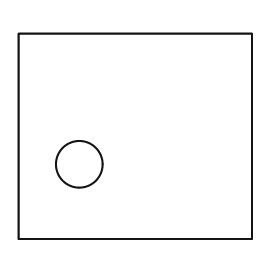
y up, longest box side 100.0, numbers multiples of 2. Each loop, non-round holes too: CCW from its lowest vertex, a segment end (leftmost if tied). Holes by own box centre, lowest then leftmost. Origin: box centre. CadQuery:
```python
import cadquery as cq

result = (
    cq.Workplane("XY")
    .moveTo(-50.0, -44.0)
    .lineTo(50.0, -44.0)
    .lineTo(50.0, 44.0)
    .lineTo(-50.0, 44.0)
    .close()
    .moveTo(-24.0, -12.0)
    .circle(10.0)
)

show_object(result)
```